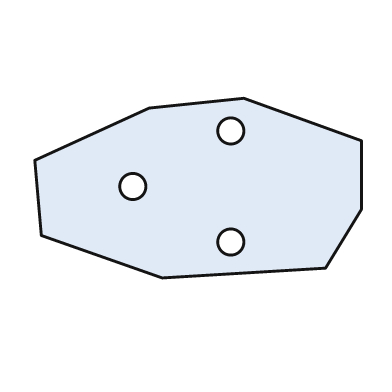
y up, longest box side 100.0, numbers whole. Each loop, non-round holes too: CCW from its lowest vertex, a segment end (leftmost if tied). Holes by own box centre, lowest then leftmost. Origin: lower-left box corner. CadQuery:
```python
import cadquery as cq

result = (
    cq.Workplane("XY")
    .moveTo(39.0, 0.0)
    .lineTo(89.0, 3.0)
    .lineTo(100.0, 21.0)
    .lineTo(100.0, 42.0)
    .lineTo(64.0, 55.0)
    .lineTo(35.0, 52.0)
    .lineTo(0.0, 36.0)
    .lineTo(2.0, 13.0)
    .close()
    .moveTo(60.0, 11.0)
    .circle(4.0)
    .moveTo(30.0, 28.0)
    .circle(4.0)
    .moveTo(60.0, 45.0)
    .circle(4.0)
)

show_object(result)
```